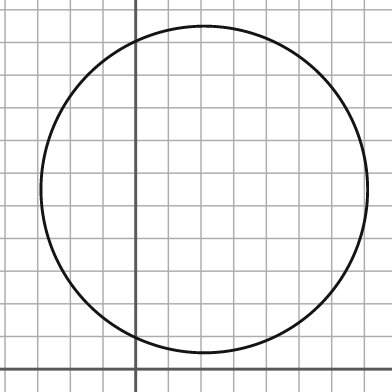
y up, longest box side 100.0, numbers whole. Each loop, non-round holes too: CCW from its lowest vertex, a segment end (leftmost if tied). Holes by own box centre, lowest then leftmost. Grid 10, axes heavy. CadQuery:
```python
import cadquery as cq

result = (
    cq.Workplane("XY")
    .moveTo(21.0, 55.0)
    .circle(50.0)
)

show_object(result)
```